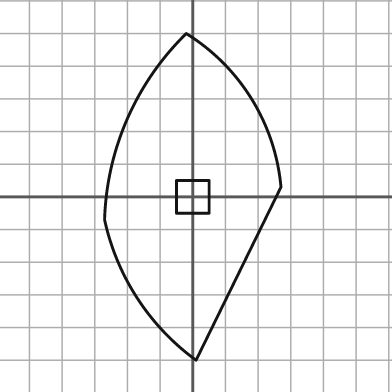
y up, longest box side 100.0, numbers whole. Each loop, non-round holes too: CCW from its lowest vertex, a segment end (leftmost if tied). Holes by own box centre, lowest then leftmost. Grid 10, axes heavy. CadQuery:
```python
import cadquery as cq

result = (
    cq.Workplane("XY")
    .moveTo(1.0, -50.0)
    .lineTo(27.0, 3.0)
    .threePointArc((18.0, 30.0), (-2.0, 50.0))
    .threePointArc((-20.0, 24.0), (-27.0, -7.0))
    .threePointArc((-17.0, -31.0), (1.0, -50.0))
    .close()
    .moveTo(-5.0, -5.0)
    .lineTo(5.0, -5.0)
    .lineTo(5.0, 5.0)
    .lineTo(-5.0, 5.0)
    .close()
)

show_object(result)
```